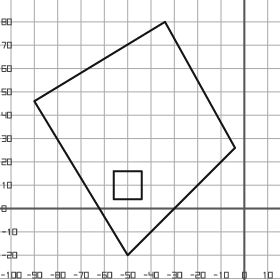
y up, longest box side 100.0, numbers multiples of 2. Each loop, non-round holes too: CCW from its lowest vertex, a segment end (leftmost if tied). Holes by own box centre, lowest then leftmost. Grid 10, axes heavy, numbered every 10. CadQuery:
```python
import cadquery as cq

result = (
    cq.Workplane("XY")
    .moveTo(-50.0, -20.0)
    .lineTo(-4.0, 26.0)
    .lineTo(-34.0, 80.0)
    .lineTo(-90.0, 46.0)
    .close()
    .moveTo(-56.0, 4.0)
    .lineTo(-44.0, 4.0)
    .lineTo(-44.0, 16.0)
    .lineTo(-56.0, 16.0)
    .close()
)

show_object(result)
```